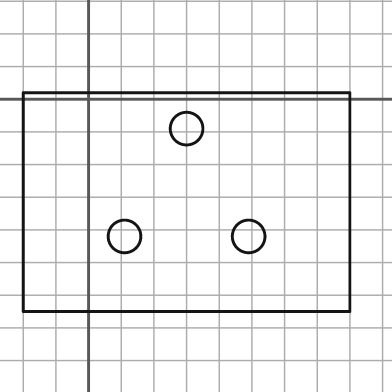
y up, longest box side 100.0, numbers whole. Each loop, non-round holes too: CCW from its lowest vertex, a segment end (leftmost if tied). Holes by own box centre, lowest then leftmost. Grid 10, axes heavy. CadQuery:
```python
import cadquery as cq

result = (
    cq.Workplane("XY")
    .moveTo(-20.0, -65.0)
    .lineTo(80.0, -65.0)
    .lineTo(80.0, 2.0)
    .lineTo(-20.0, 2.0)
    .close()
    .moveTo(11.0, -42.0)
    .circle(5.0)
    .moveTo(49.0, -42.0)
    .circle(5.0)
    .moveTo(30.0, -9.0)
    .circle(5.0)
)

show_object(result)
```